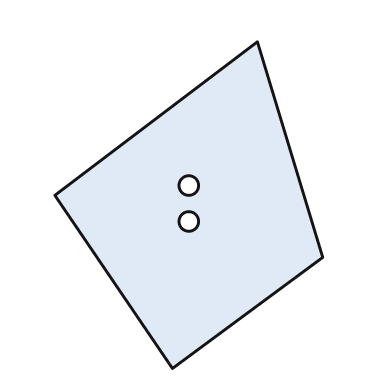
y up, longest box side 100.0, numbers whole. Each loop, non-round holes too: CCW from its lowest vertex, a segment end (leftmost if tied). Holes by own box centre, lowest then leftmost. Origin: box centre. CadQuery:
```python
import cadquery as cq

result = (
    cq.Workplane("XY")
    .moveTo(-5.0, -50.0)
    .lineTo(41.0, -16.0)
    .lineTo(21.0, 50.0)
    .lineTo(-41.0, 3.0)
    .close()
    .moveTo(0.0, -5.0)
    .circle(3.0)
    .moveTo(0.0, 6.0)
    .circle(3.0)
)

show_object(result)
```